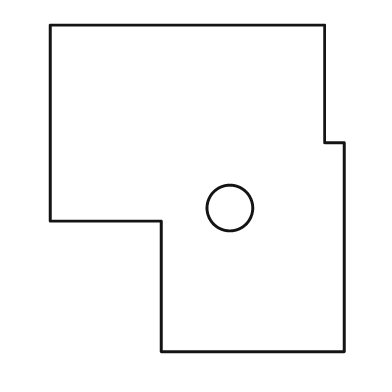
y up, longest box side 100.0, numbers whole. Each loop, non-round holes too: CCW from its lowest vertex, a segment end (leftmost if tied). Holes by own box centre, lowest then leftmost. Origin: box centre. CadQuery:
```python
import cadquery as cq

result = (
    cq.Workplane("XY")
    .moveTo(-11.0, -50.0)
    .lineTo(45.0, -50.0)
    .lineTo(45.0, 14.0)
    .lineTo(39.0, 14.0)
    .lineTo(39.0, 50.0)
    .lineTo(-45.0, 50.0)
    .lineTo(-45.0, -10.0)
    .lineTo(-11.0, -10.0)
    .close()
    .moveTo(10.0, -6.0)
    .circle(7.0)
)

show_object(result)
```